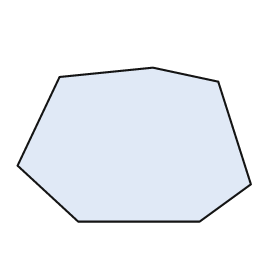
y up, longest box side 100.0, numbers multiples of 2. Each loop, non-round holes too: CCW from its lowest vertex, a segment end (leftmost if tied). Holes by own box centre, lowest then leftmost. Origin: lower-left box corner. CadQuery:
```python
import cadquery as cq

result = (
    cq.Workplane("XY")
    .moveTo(26.0, 0.0)
    .lineTo(78.0, 0.0)
    .lineTo(100.0, 16.0)
    .lineTo(86.0, 60.0)
    .lineTo(58.0, 66.0)
    .lineTo(18.0, 62.0)
    .lineTo(0.0, 24.0)
    .close()
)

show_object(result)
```